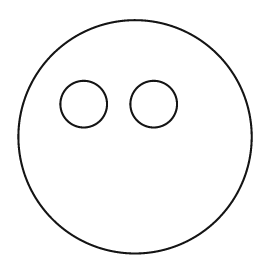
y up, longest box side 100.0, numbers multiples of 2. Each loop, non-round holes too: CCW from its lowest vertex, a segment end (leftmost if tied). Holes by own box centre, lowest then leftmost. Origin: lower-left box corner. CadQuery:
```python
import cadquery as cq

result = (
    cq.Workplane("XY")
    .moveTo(50.0, 50.0)
    .circle(50.0)
    .moveTo(28.0, 64.0)
    .circle(10.0)
    .moveTo(58.0, 64.0)
    .circle(10.0)
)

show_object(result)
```